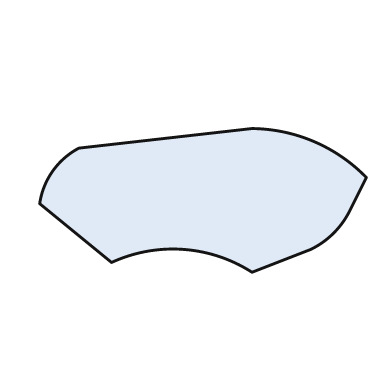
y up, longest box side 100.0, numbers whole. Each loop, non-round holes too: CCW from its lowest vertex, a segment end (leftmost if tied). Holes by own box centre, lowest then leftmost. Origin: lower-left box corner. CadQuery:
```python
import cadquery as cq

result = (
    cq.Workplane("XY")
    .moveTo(65.0, 0.0)
    .lineTo(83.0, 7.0)
    .threePointArc((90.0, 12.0), (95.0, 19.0))
    .lineTo(100.0, 29.0)
    .threePointArc((84.0, 40.0), (65.0, 44.0))
    .lineTo(12.0, 38.0)
    .threePointArc((4.0, 31.0), (0.0, 21.0))
    .lineTo(22.0, 3.0)
    .threePointArc((44.0, 7.0), (65.0, 0.0))
    .close()
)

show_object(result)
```